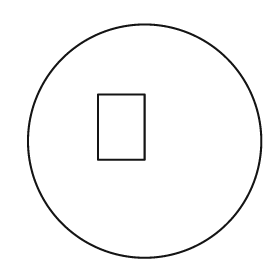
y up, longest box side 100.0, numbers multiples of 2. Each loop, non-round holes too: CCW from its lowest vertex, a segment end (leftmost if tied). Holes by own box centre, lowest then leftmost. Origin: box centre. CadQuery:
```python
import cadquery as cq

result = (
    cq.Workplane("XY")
    .moveTo(0.0, 0.0)
    .circle(50.0)
    .moveTo(-20.0, -8.0)
    .lineTo(0.0, -8.0)
    .lineTo(0.0, 20.0)
    .lineTo(-20.0, 20.0)
    .close()
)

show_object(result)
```